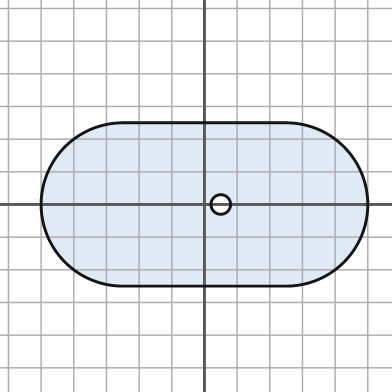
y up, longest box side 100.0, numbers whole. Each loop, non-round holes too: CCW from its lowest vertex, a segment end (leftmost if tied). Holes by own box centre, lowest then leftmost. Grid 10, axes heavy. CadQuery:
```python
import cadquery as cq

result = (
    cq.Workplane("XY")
    .moveTo(-25.0, -25.0)
    .lineTo(25.0, -25.0)
    .threePointArc((50.0, 0.0), (25.0, 25.0))
    .lineTo(-25.0, 25.0)
    .threePointArc((-50.0, 0.0), (-25.0, -25.0))
    .close()
    .moveTo(5.0, 0.0)
    .circle(3.0)
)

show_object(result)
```